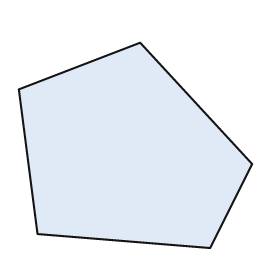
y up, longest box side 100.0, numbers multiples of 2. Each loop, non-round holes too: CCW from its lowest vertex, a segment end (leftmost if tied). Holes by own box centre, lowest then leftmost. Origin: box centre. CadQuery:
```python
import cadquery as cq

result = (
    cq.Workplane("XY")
    .moveTo(32.0, -44.0)
    .lineTo(50.0, -8.0)
    .lineTo(2.0, 44.0)
    .lineTo(-50.0, 24.0)
    .lineTo(-42.0, -38.0)
    .close()
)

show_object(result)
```